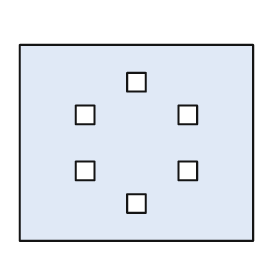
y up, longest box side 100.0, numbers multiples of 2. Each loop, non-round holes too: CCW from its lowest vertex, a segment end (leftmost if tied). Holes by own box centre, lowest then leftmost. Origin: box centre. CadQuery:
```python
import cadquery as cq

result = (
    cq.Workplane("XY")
    .moveTo(-50.0, -42.0)
    .lineTo(50.0, -42.0)
    .lineTo(50.0, 42.0)
    .lineTo(-50.0, 42.0)
    .close()
    .moveTo(-4.0, -30.0)
    .lineTo(4.0, -30.0)
    .lineTo(4.0, -22.0)
    .lineTo(-4.0, -22.0)
    .close()
    .moveTo(-26.0, -16.0)
    .lineTo(-18.0, -16.0)
    .lineTo(-18.0, -8.0)
    .lineTo(-26.0, -8.0)
    .close()
    .moveTo(18.0, -16.0)
    .lineTo(26.0, -16.0)
    .lineTo(26.0, -8.0)
    .lineTo(18.0, -8.0)
    .close()
    .moveTo(-26.0, 8.0)
    .lineTo(-18.0, 8.0)
    .lineTo(-18.0, 16.0)
    .lineTo(-26.0, 16.0)
    .close()
    .moveTo(18.0, 8.0)
    .lineTo(26.0, 8.0)
    .lineTo(26.0, 16.0)
    .lineTo(18.0, 16.0)
    .close()
    .moveTo(-4.0, 22.0)
    .lineTo(4.0, 22.0)
    .lineTo(4.0, 30.0)
    .lineTo(-4.0, 30.0)
    .close()
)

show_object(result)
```